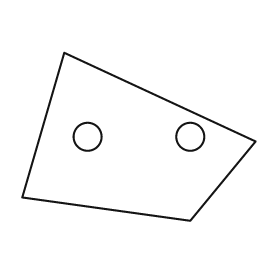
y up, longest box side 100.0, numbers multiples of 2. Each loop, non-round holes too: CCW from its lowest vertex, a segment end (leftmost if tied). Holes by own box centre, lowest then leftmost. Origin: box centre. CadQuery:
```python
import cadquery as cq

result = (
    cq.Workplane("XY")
    .moveTo(22.0, -36.0)
    .lineTo(50.0, -2.0)
    .lineTo(-32.0, 36.0)
    .lineTo(-50.0, -26.0)
    .close()
    .moveTo(-22.0, 0.0)
    .circle(6.0)
    .moveTo(22.0, 0.0)
    .circle(6.0)
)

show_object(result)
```